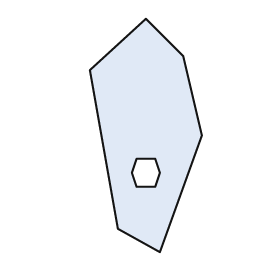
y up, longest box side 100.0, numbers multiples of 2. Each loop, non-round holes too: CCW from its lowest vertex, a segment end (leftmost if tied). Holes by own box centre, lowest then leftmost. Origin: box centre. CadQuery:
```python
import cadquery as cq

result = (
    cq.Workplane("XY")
    .moveTo(6.0, -50.0)
    .lineTo(24.0, 0.0)
    .lineTo(16.0, 34.0)
    .lineTo(0.0, 50.0)
    .lineTo(-24.0, 28.0)
    .lineTo(-12.0, -40.0)
    .close()
    .moveTo(-4.0, -22.0)
    .lineTo(4.0, -22.0)
    .lineTo(6.0, -16.0)
    .lineTo(4.0, -10.0)
    .lineTo(-4.0, -10.0)
    .lineTo(-6.0, -16.0)
    .close()
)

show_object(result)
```